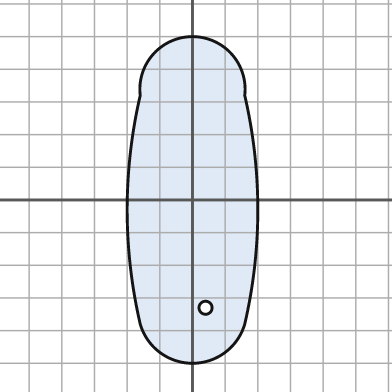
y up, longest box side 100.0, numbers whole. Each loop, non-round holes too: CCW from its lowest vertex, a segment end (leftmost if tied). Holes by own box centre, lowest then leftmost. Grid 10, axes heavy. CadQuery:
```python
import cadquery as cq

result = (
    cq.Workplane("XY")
    .moveTo(-16.0, -38.0)
    .threePointArc((0.0, -50.0), (16.0, -38.0))
    .threePointArc((20.0, -3.0), (16.0, 32.0))
    .threePointArc((0.0, 50.0), (-16.0, 32.0))
    .threePointArc((-20.0, -3.0), (-16.0, -38.0))
    .close()
    .moveTo(4.0, -33.0)
    .circle(2.0)
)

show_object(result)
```